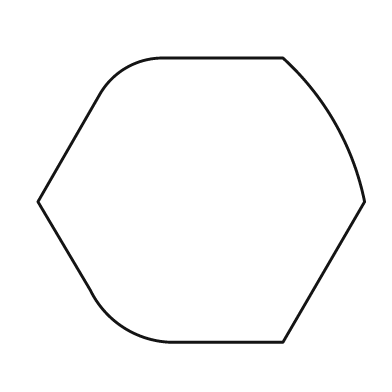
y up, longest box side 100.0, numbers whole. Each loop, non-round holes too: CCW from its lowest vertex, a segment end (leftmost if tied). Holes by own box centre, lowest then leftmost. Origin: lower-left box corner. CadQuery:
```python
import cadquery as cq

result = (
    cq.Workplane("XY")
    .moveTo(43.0, 0.0)
    .lineTo(75.0, 0.0)
    .lineTo(100.0, 43.0)
    .threePointArc((91.0, 67.0), (75.0, 87.0))
    .lineTo(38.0, 87.0)
    .threePointArc((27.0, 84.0), (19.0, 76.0))
    .lineTo(0.0, 43.0)
    .lineTo(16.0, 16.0)
    .threePointArc((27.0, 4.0), (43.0, 0.0))
    .close()
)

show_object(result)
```